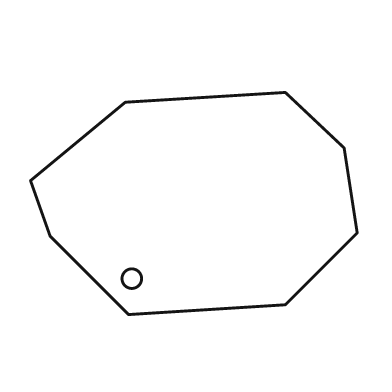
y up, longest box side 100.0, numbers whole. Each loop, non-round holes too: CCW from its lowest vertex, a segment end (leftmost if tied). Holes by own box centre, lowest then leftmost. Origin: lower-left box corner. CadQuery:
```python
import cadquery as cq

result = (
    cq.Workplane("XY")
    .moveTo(30.0, 0.0)
    .lineTo(78.0, 3.0)
    .lineTo(100.0, 25.0)
    .lineTo(96.0, 51.0)
    .lineTo(78.0, 68.0)
    .lineTo(29.0, 65.0)
    .lineTo(0.0, 41.0)
    .lineTo(6.0, 24.0)
    .close()
    .moveTo(31.0, 11.0)
    .circle(3.0)
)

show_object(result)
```